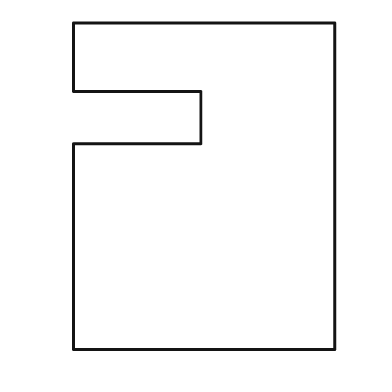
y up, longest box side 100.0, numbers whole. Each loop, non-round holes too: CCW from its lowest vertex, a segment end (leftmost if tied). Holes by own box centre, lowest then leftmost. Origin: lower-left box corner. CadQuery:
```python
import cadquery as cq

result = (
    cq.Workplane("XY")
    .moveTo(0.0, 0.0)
    .lineTo(80.0, 0.0)
    .lineTo(80.0, 100.0)
    .lineTo(0.0, 100.0)
    .lineTo(0.0, 79.0)
    .lineTo(39.0, 79.0)
    .lineTo(39.0, 63.0)
    .lineTo(0.0, 63.0)
    .close()
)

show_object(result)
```